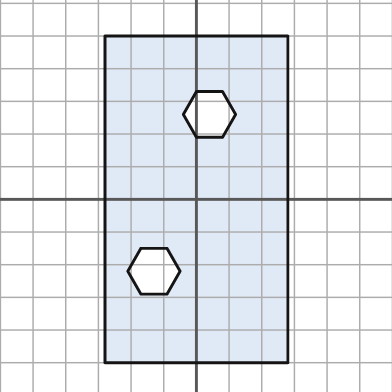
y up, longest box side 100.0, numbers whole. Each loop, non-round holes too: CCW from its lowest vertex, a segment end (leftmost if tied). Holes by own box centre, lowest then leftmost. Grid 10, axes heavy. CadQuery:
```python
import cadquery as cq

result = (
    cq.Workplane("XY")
    .moveTo(-28.0, -50.0)
    .lineTo(28.0, -50.0)
    .lineTo(28.0, 50.0)
    .lineTo(-28.0, 50.0)
    .close()
    .moveTo(-17.0, -29.0)
    .lineTo(-9.0, -29.0)
    .lineTo(-5.0, -22.0)
    .lineTo(-9.0, -15.0)
    .lineTo(-17.0, -15.0)
    .lineTo(-21.0, -22.0)
    .close()
    .moveTo(0.0, 19.0)
    .lineTo(8.0, 19.0)
    .lineTo(12.0, 26.0)
    .lineTo(8.0, 33.0)
    .lineTo(0.0, 33.0)
    .lineTo(-4.0, 26.0)
    .close()
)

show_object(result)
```